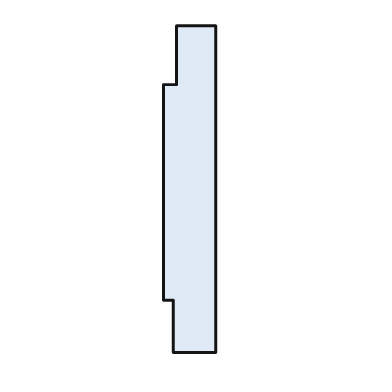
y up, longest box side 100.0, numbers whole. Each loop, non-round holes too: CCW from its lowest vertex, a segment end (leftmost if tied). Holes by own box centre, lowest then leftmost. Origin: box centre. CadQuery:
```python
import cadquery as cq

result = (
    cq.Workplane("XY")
    .moveTo(-5.0, -50.0)
    .lineTo(8.0, -50.0)
    .lineTo(8.0, 50.0)
    .lineTo(-4.0, 50.0)
    .lineTo(-4.0, 32.0)
    .lineTo(-8.0, 32.0)
    .lineTo(-8.0, -34.0)
    .lineTo(-5.0, -34.0)
    .close()
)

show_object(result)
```